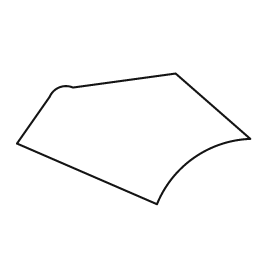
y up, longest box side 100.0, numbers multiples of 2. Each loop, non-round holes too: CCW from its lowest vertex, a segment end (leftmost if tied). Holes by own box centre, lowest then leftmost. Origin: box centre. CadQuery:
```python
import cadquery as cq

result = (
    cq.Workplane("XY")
    .moveTo(10.0, -28.0)
    .threePointArc((26.0, -8.0), (50.0, 0.0))
    .lineTo(18.0, 28.0)
    .lineTo(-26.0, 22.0)
    .threePointArc((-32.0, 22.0), (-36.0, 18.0))
    .lineTo(-50.0, -2.0)
    .close()
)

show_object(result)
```